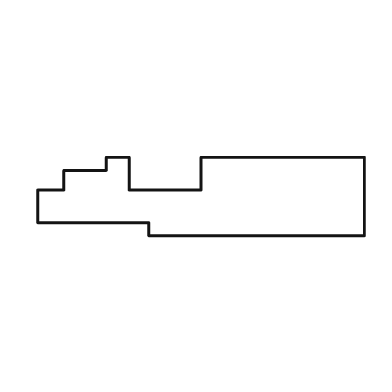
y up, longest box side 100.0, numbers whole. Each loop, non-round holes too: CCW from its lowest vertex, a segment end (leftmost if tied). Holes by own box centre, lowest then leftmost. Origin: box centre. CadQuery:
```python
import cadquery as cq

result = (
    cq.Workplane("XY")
    .moveTo(-16.0, -12.0)
    .lineTo(50.0, -12.0)
    .lineTo(50.0, 12.0)
    .lineTo(0.0, 12.0)
    .lineTo(0.0, 2.0)
    .lineTo(-22.0, 2.0)
    .lineTo(-22.0, 12.0)
    .lineTo(-29.0, 12.0)
    .lineTo(-29.0, 8.0)
    .lineTo(-42.0, 8.0)
    .lineTo(-42.0, 2.0)
    .lineTo(-50.0, 2.0)
    .lineTo(-50.0, -8.0)
    .lineTo(-16.0, -8.0)
    .close()
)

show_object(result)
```